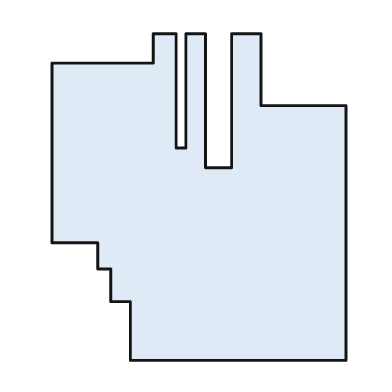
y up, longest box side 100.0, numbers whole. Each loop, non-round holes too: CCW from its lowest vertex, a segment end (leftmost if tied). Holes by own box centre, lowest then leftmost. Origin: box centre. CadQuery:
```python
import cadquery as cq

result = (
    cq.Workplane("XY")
    .moveTo(-21.0, -50.0)
    .lineTo(45.0, -50.0)
    .lineTo(45.0, 28.0)
    .lineTo(19.0, 28.0)
    .lineTo(19.0, 50.0)
    .lineTo(10.0, 50.0)
    .lineTo(10.0, 9.0)
    .lineTo(2.0, 9.0)
    .lineTo(2.0, 50.0)
    .lineTo(-4.0, 50.0)
    .lineTo(-4.0, 15.0)
    .lineTo(-7.0, 15.0)
    .lineTo(-7.0, 50.0)
    .lineTo(-14.0, 50.0)
    .lineTo(-14.0, 41.0)
    .lineTo(-45.0, 41.0)
    .lineTo(-45.0, -14.0)
    .lineTo(-31.0, -14.0)
    .lineTo(-31.0, -22.0)
    .lineTo(-27.0, -22.0)
    .lineTo(-27.0, -32.0)
    .lineTo(-21.0, -32.0)
    .close()
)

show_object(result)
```